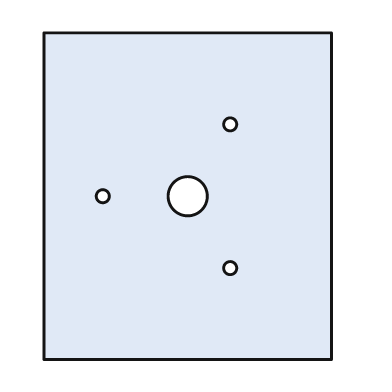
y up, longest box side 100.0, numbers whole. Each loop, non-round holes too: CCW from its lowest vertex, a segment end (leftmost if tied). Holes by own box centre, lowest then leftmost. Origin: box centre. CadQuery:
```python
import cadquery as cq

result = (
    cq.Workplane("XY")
    .moveTo(-44.0, -50.0)
    .lineTo(44.0, -50.0)
    .lineTo(44.0, 50.0)
    .lineTo(-44.0, 50.0)
    .close()
    .moveTo(13.0, -22.0)
    .circle(2.0)
    .moveTo(-26.0, 0.0)
    .circle(2.0)
    .moveTo(0.0, 0.0)
    .circle(6.0)
    .moveTo(13.0, 22.0)
    .circle(2.0)
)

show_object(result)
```